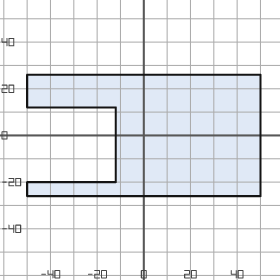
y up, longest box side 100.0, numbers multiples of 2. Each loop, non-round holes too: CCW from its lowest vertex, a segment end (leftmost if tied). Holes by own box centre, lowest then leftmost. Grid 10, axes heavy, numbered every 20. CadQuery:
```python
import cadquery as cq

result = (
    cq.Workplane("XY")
    .moveTo(-50.0, -26.0)
    .lineTo(50.0, -26.0)
    .lineTo(50.0, 26.0)
    .lineTo(-50.0, 26.0)
    .lineTo(-50.0, 12.0)
    .lineTo(-12.0, 12.0)
    .lineTo(-12.0, -20.0)
    .lineTo(-50.0, -20.0)
    .close()
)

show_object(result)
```